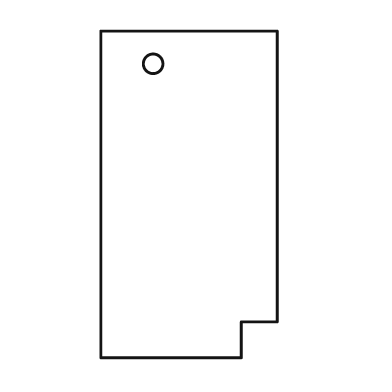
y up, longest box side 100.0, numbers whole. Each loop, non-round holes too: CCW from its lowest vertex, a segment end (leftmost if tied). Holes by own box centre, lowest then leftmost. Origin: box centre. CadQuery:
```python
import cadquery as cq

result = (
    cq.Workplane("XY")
    .moveTo(-27.0, -50.0)
    .lineTo(16.0, -50.0)
    .lineTo(16.0, -39.0)
    .lineTo(27.0, -39.0)
    .lineTo(27.0, 50.0)
    .lineTo(-27.0, 50.0)
    .close()
    .moveTo(-11.0, 40.0)
    .circle(3.0)
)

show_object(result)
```